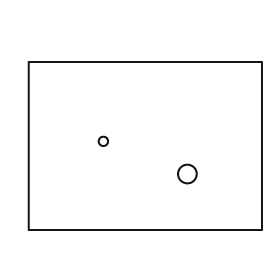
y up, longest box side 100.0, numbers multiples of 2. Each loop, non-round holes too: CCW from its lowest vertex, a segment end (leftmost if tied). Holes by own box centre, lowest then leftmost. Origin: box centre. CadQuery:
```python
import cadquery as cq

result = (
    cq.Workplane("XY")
    .moveTo(-50.0, -36.0)
    .lineTo(50.0, -36.0)
    .lineTo(50.0, 36.0)
    .lineTo(-50.0, 36.0)
    .close()
    .moveTo(18.0, -12.0)
    .circle(4.0)
    .moveTo(-18.0, 2.0)
    .circle(2.0)
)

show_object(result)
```